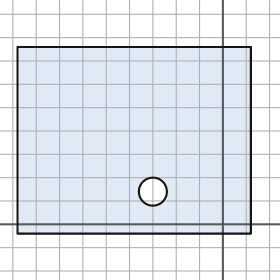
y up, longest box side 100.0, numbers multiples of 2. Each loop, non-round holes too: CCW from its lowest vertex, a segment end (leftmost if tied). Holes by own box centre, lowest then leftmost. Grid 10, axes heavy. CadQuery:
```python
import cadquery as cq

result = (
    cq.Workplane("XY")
    .moveTo(-88.0, -4.0)
    .lineTo(12.0, -4.0)
    .lineTo(12.0, 76.0)
    .lineTo(-88.0, 76.0)
    .close()
    .moveTo(-30.0, 14.0)
    .circle(6.0)
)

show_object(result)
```